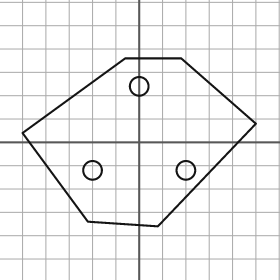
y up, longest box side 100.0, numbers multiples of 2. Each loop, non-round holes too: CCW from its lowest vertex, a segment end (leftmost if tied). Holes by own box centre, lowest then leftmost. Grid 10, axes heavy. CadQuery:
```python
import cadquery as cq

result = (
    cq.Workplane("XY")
    .moveTo(8.0, -36.0)
    .lineTo(50.0, 8.0)
    .lineTo(18.0, 36.0)
    .lineTo(-6.0, 36.0)
    .lineTo(-50.0, 4.0)
    .lineTo(-22.0, -34.0)
    .close()
    .moveTo(-20.0, -12.0)
    .circle(4.0)
    .moveTo(20.0, -12.0)
    .circle(4.0)
    .moveTo(0.0, 24.0)
    .circle(4.0)
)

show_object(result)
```